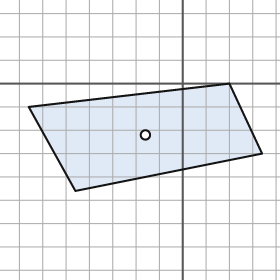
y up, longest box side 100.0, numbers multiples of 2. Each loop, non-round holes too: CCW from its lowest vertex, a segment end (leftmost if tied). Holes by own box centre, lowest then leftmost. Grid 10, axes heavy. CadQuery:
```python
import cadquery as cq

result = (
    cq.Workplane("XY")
    .moveTo(-46.0, -46.0)
    .lineTo(34.0, -30.0)
    .lineTo(20.0, 0.0)
    .lineTo(-66.0, -10.0)
    .close()
    .moveTo(-16.0, -22.0)
    .circle(2.0)
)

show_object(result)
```